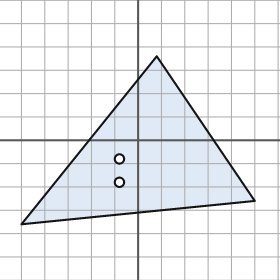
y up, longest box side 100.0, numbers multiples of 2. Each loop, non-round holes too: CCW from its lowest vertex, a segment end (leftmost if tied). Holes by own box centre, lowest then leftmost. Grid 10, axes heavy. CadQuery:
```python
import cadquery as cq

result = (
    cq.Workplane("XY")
    .moveTo(-50.0, -36.0)
    .lineTo(50.0, -26.0)
    .lineTo(8.0, 36.0)
    .close()
    .moveTo(-8.0, -18.0)
    .circle(2.0)
    .moveTo(-8.0, -8.0)
    .circle(2.0)
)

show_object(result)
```